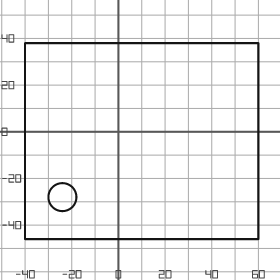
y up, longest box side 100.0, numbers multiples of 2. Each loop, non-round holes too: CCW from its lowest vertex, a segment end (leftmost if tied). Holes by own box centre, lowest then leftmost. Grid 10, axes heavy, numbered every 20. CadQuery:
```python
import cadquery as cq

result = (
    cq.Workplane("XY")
    .moveTo(-40.0, -46.0)
    .lineTo(60.0, -46.0)
    .lineTo(60.0, 38.0)
    .lineTo(-40.0, 38.0)
    .close()
    .moveTo(-24.0, -28.0)
    .circle(6.0)
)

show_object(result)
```